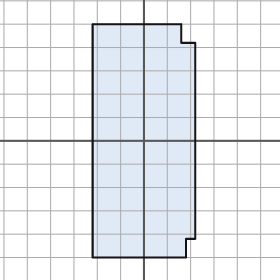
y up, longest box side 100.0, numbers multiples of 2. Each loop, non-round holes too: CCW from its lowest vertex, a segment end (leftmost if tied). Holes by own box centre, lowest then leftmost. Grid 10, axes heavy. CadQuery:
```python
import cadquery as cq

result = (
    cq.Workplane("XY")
    .moveTo(-22.0, -50.0)
    .lineTo(18.0, -50.0)
    .lineTo(18.0, -42.0)
    .lineTo(22.0, -42.0)
    .lineTo(22.0, 42.0)
    .lineTo(16.0, 42.0)
    .lineTo(16.0, 50.0)
    .lineTo(-22.0, 50.0)
    .close()
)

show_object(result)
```